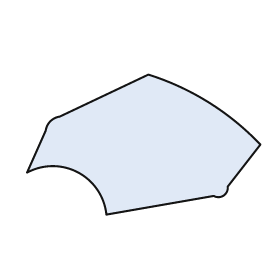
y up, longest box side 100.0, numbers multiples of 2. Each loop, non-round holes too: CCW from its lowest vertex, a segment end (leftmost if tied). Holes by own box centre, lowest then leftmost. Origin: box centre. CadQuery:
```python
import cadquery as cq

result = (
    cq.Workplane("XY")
    .moveTo(-16.0, -30.0)
    .lineTo(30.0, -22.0)
    .threePointArc((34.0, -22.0), (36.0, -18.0))
    .lineTo(50.0, 0.0)
    .threePointArc((28.0, 18.0), (2.0, 30.0))
    .lineTo(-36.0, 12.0)
    .threePointArc((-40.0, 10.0), (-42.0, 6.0))
    .lineTo(-50.0, -12.0)
    .threePointArc((-28.0, -12.0), (-16.0, -30.0))
    .close()
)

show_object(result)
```